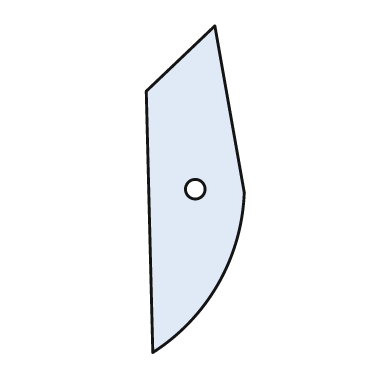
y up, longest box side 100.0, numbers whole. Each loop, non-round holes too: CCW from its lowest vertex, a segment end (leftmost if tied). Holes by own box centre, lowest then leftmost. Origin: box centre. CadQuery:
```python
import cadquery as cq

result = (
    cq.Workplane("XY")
    .moveTo(-13.0, -50.0)
    .threePointArc((7.0, -29.0), (15.0, -1.0))
    .lineTo(6.0, 50.0)
    .lineTo(-15.0, 30.0)
    .close()
    .moveTo(0.0, 0.0)
    .circle(3.0)
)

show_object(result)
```